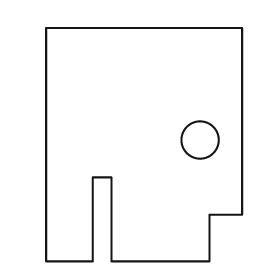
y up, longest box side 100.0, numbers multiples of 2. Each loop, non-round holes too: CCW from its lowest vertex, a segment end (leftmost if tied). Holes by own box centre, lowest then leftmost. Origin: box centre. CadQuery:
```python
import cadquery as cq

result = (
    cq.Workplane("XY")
    .moveTo(-42.0, -50.0)
    .lineTo(-22.0, -50.0)
    .lineTo(-22.0, -14.0)
    .lineTo(-14.0, -14.0)
    .lineTo(-14.0, -50.0)
    .lineTo(28.0, -50.0)
    .lineTo(28.0, -30.0)
    .lineTo(42.0, -30.0)
    .lineTo(42.0, 50.0)
    .lineTo(-42.0, 50.0)
    .close()
    .moveTo(24.0, 2.0)
    .circle(8.0)
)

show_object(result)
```